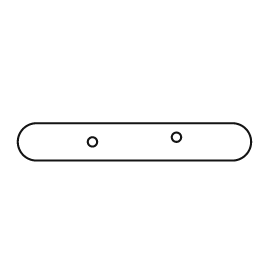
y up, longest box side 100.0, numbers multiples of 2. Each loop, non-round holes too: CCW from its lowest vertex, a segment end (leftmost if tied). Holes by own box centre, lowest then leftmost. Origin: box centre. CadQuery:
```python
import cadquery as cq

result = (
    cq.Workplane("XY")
    .moveTo(-42.0, -8.0)
    .lineTo(42.0, -8.0)
    .threePointArc((50.0, 0.0), (42.0, 8.0))
    .lineTo(-42.0, 8.0)
    .threePointArc((-50.0, 0.0), (-42.0, -8.0))
    .close()
    .moveTo(-18.0, 0.0)
    .circle(2.0)
    .moveTo(18.0, 2.0)
    .circle(2.0)
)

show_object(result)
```